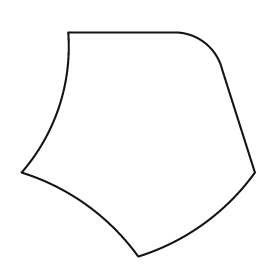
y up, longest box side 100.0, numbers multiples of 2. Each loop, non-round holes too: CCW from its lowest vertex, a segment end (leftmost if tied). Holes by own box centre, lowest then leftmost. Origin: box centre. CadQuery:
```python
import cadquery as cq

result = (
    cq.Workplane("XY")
    .moveTo(0.0, -48.0)
    .threePointArc((28.0, -34.0), (50.0, -12.0))
    .lineTo(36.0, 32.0)
    .threePointArc((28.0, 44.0), (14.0, 48.0))
    .lineTo(-30.0, 48.0)
    .threePointArc((-34.0, 16.0), (-50.0, -12.0))
    .threePointArc((-22.0, -26.0), (0.0, -48.0))
    .close()
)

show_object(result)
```